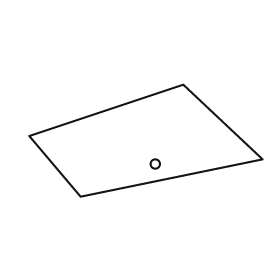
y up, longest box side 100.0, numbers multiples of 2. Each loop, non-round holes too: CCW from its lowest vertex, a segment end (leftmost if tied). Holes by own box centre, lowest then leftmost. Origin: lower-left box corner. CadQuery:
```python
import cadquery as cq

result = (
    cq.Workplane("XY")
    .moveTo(22.0, 0.0)
    .lineTo(100.0, 16.0)
    .lineTo(66.0, 48.0)
    .lineTo(0.0, 26.0)
    .close()
    .moveTo(54.0, 14.0)
    .circle(2.0)
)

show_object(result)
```